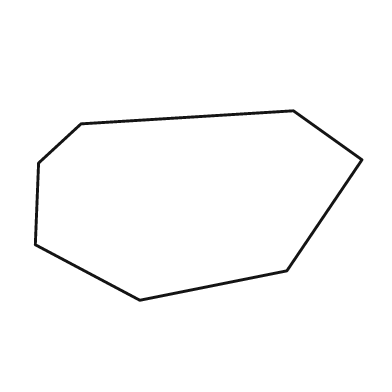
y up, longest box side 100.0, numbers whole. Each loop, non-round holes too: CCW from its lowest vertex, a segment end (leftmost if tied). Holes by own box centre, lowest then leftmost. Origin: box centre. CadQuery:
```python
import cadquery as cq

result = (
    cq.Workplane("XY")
    .moveTo(-18.0, -29.0)
    .lineTo(27.0, -20.0)
    .lineTo(50.0, 14.0)
    .lineTo(29.0, 29.0)
    .lineTo(-36.0, 25.0)
    .lineTo(-49.0, 13.0)
    .lineTo(-50.0, -12.0)
    .close()
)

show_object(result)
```